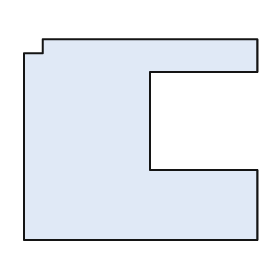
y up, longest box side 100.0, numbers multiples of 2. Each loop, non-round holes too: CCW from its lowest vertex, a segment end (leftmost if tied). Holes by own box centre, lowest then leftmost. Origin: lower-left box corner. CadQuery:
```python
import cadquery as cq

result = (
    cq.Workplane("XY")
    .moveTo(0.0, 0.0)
    .lineTo(100.0, 0.0)
    .lineTo(100.0, 30.0)
    .lineTo(54.0, 30.0)
    .lineTo(54.0, 72.0)
    .lineTo(100.0, 72.0)
    .lineTo(100.0, 86.0)
    .lineTo(8.0, 86.0)
    .lineTo(8.0, 80.0)
    .lineTo(0.0, 80.0)
    .close()
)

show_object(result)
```